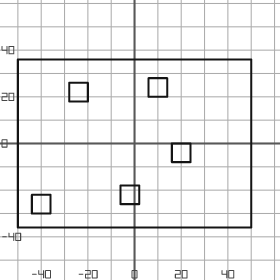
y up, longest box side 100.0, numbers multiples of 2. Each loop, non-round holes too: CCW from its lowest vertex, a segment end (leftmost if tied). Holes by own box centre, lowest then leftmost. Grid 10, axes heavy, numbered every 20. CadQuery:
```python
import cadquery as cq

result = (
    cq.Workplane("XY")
    .moveTo(-50.0, -36.0)
    .lineTo(50.0, -36.0)
    .lineTo(50.0, 36.0)
    .lineTo(-50.0, 36.0)
    .close()
    .moveTo(-44.0, -30.0)
    .lineTo(-36.0, -30.0)
    .lineTo(-36.0, -22.0)
    .lineTo(-44.0, -22.0)
    .close()
    .moveTo(-6.0, -26.0)
    .lineTo(2.0, -26.0)
    .lineTo(2.0, -18.0)
    .lineTo(-6.0, -18.0)
    .close()
    .moveTo(16.0, -8.0)
    .lineTo(24.0, -8.0)
    .lineTo(24.0, 0.0)
    .lineTo(16.0, 0.0)
    .close()
    .moveTo(-28.0, 18.0)
    .lineTo(-20.0, 18.0)
    .lineTo(-20.0, 26.0)
    .lineTo(-28.0, 26.0)
    .close()
    .moveTo(6.0, 20.0)
    .lineTo(14.0, 20.0)
    .lineTo(14.0, 28.0)
    .lineTo(6.0, 28.0)
    .close()
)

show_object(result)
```